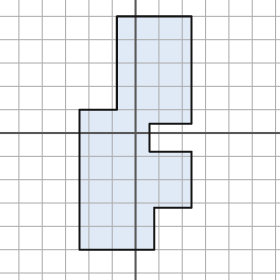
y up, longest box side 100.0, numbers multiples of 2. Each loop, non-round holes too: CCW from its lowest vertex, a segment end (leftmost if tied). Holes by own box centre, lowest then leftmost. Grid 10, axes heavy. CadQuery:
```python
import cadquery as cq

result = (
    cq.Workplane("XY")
    .moveTo(-24.0, -50.0)
    .lineTo(8.0, -50.0)
    .lineTo(8.0, -32.0)
    .lineTo(24.0, -32.0)
    .lineTo(24.0, -8.0)
    .lineTo(6.0, -8.0)
    .lineTo(6.0, 4.0)
    .lineTo(24.0, 4.0)
    .lineTo(24.0, 50.0)
    .lineTo(-8.0, 50.0)
    .lineTo(-8.0, 10.0)
    .lineTo(-24.0, 10.0)
    .close()
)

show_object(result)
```